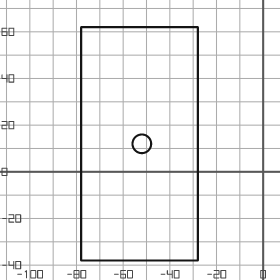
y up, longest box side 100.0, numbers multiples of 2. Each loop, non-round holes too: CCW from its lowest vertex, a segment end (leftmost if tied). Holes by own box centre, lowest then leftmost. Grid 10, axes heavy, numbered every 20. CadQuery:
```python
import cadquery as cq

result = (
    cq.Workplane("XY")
    .moveTo(-78.0, -38.0)
    .lineTo(-28.0, -38.0)
    .lineTo(-28.0, 62.0)
    .lineTo(-78.0, 62.0)
    .close()
    .moveTo(-52.0, 12.0)
    .circle(4.0)
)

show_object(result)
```